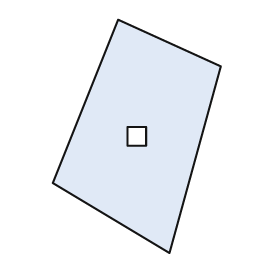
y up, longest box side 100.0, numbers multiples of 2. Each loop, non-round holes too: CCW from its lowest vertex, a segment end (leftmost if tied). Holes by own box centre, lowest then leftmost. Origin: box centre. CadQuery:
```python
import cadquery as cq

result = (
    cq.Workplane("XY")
    .moveTo(14.0, -50.0)
    .lineTo(36.0, 30.0)
    .lineTo(-8.0, 50.0)
    .lineTo(-36.0, -20.0)
    .close()
    .moveTo(-4.0, -4.0)
    .lineTo(4.0, -4.0)
    .lineTo(4.0, 4.0)
    .lineTo(-4.0, 4.0)
    .close()
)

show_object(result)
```